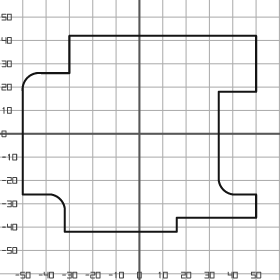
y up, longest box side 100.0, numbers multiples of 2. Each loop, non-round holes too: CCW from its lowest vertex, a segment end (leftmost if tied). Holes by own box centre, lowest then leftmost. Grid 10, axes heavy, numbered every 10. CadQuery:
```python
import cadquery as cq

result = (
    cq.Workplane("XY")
    .moveTo(-32.0, -42.0)
    .lineTo(16.0, -42.0)
    .lineTo(16.0, -36.0)
    .lineTo(50.0, -36.0)
    .lineTo(50.0, -26.0)
    .lineTo(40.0, -26.0)
    .threePointArc((36.0, -24.0), (34.0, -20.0))
    .lineTo(34.0, 18.0)
    .lineTo(50.0, 18.0)
    .lineTo(50.0, 42.0)
    .lineTo(-30.0, 42.0)
    .lineTo(-30.0, 26.0)
    .lineTo(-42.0, 26.0)
    .threePointArc((-48.0, 24.0), (-50.0, 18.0))
    .lineTo(-50.0, -26.0)
    .lineTo(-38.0, -26.0)
    .threePointArc((-34.0, -28.0), (-32.0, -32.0))
    .close()
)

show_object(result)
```